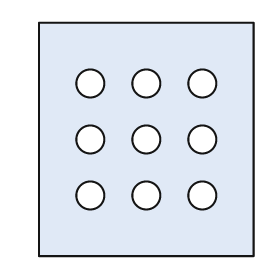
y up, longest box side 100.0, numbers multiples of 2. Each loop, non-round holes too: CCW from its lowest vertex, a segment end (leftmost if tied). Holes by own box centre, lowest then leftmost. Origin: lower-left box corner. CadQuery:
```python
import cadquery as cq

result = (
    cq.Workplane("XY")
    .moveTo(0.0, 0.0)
    .lineTo(92.0, 0.0)
    .lineTo(92.0, 100.0)
    .lineTo(0.0, 100.0)
    .close()
    .moveTo(22.0, 26.0)
    .circle(6.0)
    .moveTo(46.0, 26.0)
    .circle(6.0)
    .moveTo(70.0, 26.0)
    .circle(6.0)
    .moveTo(22.0, 50.0)
    .circle(6.0)
    .moveTo(46.0, 50.0)
    .circle(6.0)
    .moveTo(70.0, 50.0)
    .circle(6.0)
    .moveTo(22.0, 74.0)
    .circle(6.0)
    .moveTo(46.0, 74.0)
    .circle(6.0)
    .moveTo(70.0, 74.0)
    .circle(6.0)
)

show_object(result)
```